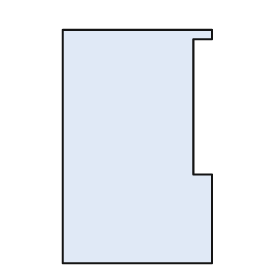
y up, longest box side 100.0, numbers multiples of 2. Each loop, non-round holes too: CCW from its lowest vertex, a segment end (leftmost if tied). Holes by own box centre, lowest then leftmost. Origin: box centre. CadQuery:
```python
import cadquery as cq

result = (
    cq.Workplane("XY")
    .moveTo(-32.0, -50.0)
    .lineTo(32.0, -50.0)
    .lineTo(32.0, -12.0)
    .lineTo(24.0, -12.0)
    .lineTo(24.0, 46.0)
    .lineTo(32.0, 46.0)
    .lineTo(32.0, 50.0)
    .lineTo(-32.0, 50.0)
    .close()
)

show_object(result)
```